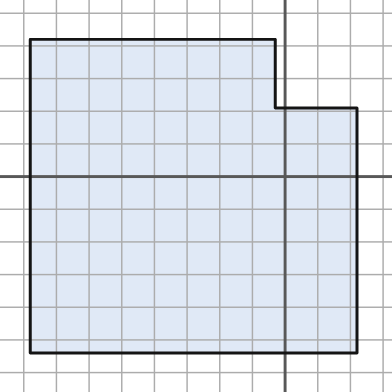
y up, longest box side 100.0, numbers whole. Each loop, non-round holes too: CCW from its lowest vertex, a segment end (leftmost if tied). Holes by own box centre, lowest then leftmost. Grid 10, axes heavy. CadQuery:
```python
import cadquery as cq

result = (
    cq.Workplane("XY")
    .moveTo(-78.0, -54.0)
    .lineTo(22.0, -54.0)
    .lineTo(22.0, 21.0)
    .lineTo(-3.0, 21.0)
    .lineTo(-3.0, 42.0)
    .lineTo(-78.0, 42.0)
    .close()
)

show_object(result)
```